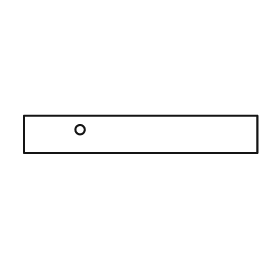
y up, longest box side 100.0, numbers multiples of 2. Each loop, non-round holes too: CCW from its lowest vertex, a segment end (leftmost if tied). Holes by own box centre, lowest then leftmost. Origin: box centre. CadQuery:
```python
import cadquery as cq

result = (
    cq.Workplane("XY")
    .moveTo(-50.0, -8.0)
    .lineTo(50.0, -8.0)
    .lineTo(50.0, 8.0)
    .lineTo(-50.0, 8.0)
    .close()
    .moveTo(-26.0, 2.0)
    .circle(2.0)
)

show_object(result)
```